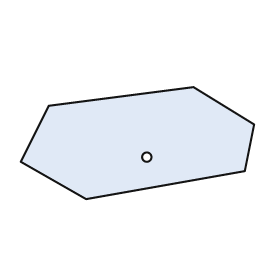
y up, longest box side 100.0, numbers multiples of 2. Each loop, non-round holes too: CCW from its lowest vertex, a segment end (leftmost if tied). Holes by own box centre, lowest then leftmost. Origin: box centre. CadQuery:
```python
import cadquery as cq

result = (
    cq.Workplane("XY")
    .moveTo(-22.0, -24.0)
    .lineTo(46.0, -12.0)
    .lineTo(50.0, 8.0)
    .lineTo(24.0, 24.0)
    .lineTo(-38.0, 16.0)
    .lineTo(-50.0, -8.0)
    .close()
    .moveTo(4.0, -6.0)
    .circle(2.0)
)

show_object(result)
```